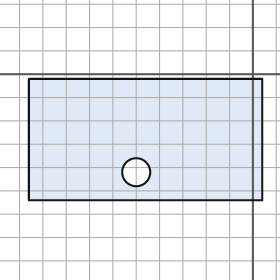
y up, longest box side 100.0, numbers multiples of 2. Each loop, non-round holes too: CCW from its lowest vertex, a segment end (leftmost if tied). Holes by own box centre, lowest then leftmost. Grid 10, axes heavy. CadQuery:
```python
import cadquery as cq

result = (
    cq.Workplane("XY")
    .moveTo(-96.0, -54.0)
    .lineTo(4.0, -54.0)
    .lineTo(4.0, -2.0)
    .lineTo(-96.0, -2.0)
    .close()
    .moveTo(-50.0, -42.0)
    .circle(6.0)
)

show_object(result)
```